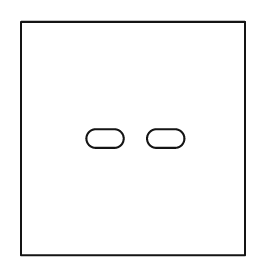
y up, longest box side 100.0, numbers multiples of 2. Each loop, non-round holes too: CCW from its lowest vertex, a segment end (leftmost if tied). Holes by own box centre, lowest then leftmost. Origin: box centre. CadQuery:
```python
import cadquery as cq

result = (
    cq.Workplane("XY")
    .moveTo(-48.0, -50.0)
    .lineTo(48.0, -50.0)
    .lineTo(48.0, 50.0)
    .lineTo(-48.0, 50.0)
    .close()
    .moveTo(-16.0, -4.0)
    .lineTo(-8.0, -4.0)
    .threePointArc((-4.0, 0.0), (-8.0, 4.0))
    .lineTo(-16.0, 4.0)
    .threePointArc((-20.0, 0.0), (-16.0, -4.0))
    .close()
    .moveTo(10.0, -4.0)
    .lineTo(18.0, -4.0)
    .threePointArc((22.0, 0.0), (18.0, 4.0))
    .lineTo(10.0, 4.0)
    .threePointArc((6.0, 0.0), (10.0, -4.0))
    .close()
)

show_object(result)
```